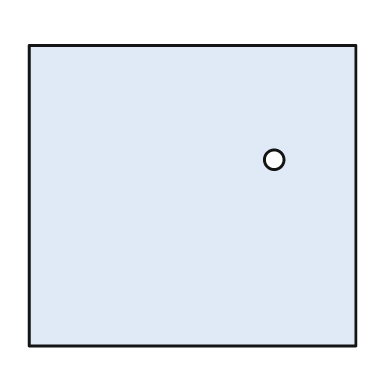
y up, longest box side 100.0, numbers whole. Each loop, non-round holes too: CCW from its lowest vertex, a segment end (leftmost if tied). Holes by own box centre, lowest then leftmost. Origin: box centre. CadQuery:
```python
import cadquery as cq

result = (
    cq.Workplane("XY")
    .moveTo(-50.0, -46.0)
    .lineTo(50.0, -46.0)
    .lineTo(50.0, 46.0)
    .lineTo(-50.0, 46.0)
    .close()
    .moveTo(25.0, 11.0)
    .circle(3.0)
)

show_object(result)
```